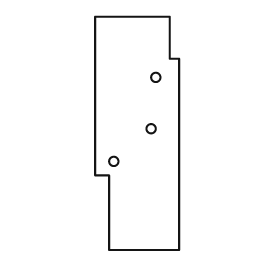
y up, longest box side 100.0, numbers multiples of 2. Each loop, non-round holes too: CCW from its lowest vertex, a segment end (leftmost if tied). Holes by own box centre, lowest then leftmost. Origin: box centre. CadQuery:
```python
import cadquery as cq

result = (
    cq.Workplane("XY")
    .moveTo(-12.0, -50.0)
    .lineTo(18.0, -50.0)
    .lineTo(18.0, 32.0)
    .lineTo(14.0, 32.0)
    .lineTo(14.0, 50.0)
    .lineTo(-18.0, 50.0)
    .lineTo(-18.0, -18.0)
    .lineTo(-12.0, -18.0)
    .close()
    .moveTo(-10.0, -12.0)
    .circle(2.0)
    .moveTo(6.0, 2.0)
    .circle(2.0)
    .moveTo(8.0, 24.0)
    .circle(2.0)
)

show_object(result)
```